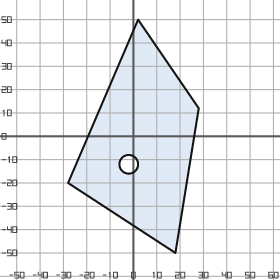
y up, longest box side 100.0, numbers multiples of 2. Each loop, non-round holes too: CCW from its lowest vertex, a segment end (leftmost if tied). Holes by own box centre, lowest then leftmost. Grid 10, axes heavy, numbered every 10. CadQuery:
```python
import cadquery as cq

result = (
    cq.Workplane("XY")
    .moveTo(18.0, -50.0)
    .lineTo(28.0, 12.0)
    .lineTo(2.0, 50.0)
    .lineTo(-28.0, -20.0)
    .close()
    .moveTo(-2.0, -12.0)
    .circle(4.0)
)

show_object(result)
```